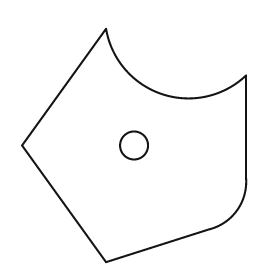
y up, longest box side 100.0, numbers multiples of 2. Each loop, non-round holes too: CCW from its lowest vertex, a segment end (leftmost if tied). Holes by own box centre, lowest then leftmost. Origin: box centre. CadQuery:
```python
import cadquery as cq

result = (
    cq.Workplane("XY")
    .moveTo(-12.0, -50.0)
    .lineTo(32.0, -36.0)
    .threePointArc((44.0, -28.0), (48.0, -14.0))
    .lineTo(48.0, 30.0)
    .threePointArc((12.0, 22.0), (-12.0, 50.0))
    .lineTo(-48.0, 0.0)
    .close()
    .moveTo(0.0, 0.0)
    .circle(6.0)
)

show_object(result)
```